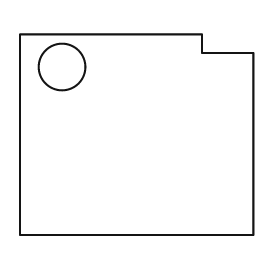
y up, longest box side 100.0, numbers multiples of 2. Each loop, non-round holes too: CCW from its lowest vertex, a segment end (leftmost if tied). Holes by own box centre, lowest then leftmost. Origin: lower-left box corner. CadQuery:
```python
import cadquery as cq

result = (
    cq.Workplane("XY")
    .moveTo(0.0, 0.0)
    .lineTo(100.0, 0.0)
    .lineTo(100.0, 78.0)
    .lineTo(78.0, 78.0)
    .lineTo(78.0, 86.0)
    .lineTo(0.0, 86.0)
    .close()
    .moveTo(18.0, 72.0)
    .circle(10.0)
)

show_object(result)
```